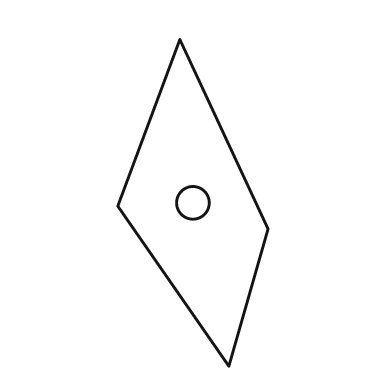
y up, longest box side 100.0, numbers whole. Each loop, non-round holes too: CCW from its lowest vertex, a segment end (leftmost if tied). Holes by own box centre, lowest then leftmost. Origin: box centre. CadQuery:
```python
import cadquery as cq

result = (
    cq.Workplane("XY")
    .moveTo(11.0, -50.0)
    .lineTo(23.0, -8.0)
    .lineTo(-4.0, 50.0)
    .lineTo(-23.0, -1.0)
    .close()
    .moveTo(0.0, 0.0)
    .circle(5.0)
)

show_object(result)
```